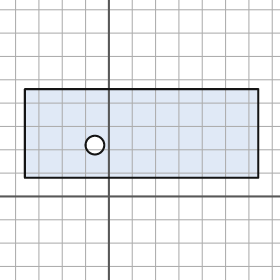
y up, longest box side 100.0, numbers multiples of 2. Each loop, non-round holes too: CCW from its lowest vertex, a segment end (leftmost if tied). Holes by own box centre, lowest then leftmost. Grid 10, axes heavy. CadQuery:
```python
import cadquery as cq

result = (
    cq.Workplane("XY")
    .moveTo(-36.0, 8.0)
    .lineTo(64.0, 8.0)
    .lineTo(64.0, 46.0)
    .lineTo(-36.0, 46.0)
    .close()
    .moveTo(-6.0, 22.0)
    .circle(4.0)
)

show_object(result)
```